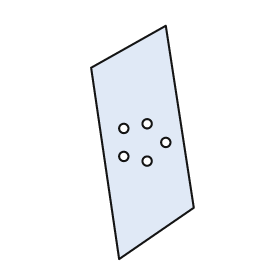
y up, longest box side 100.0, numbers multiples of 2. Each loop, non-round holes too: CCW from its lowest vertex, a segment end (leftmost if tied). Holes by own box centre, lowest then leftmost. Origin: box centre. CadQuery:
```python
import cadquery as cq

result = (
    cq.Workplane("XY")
    .moveTo(-10.0, -50.0)
    .lineTo(22.0, -28.0)
    .lineTo(10.0, 50.0)
    .lineTo(-22.0, 32.0)
    .close()
    .moveTo(2.0, -8.0)
    .circle(2.0)
    .moveTo(-8.0, -6.0)
    .circle(2.0)
    .moveTo(10.0, 0.0)
    .circle(2.0)
    .moveTo(-8.0, 6.0)
    .circle(2.0)
    .moveTo(2.0, 8.0)
    .circle(2.0)
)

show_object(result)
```